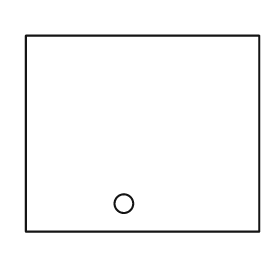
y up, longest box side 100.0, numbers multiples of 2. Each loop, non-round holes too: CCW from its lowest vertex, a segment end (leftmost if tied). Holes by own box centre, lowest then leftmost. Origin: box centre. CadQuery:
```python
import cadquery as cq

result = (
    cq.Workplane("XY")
    .moveTo(-50.0, -42.0)
    .lineTo(50.0, -42.0)
    .lineTo(50.0, 42.0)
    .lineTo(-50.0, 42.0)
    .close()
    .moveTo(-8.0, -30.0)
    .circle(4.0)
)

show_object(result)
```